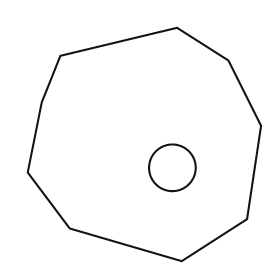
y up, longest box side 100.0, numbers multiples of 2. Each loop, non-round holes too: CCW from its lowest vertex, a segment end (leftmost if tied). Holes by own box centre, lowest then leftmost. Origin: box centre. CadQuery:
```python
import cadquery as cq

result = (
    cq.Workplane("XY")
    .moveTo(16.0, -50.0)
    .lineTo(44.0, -32.0)
    .lineTo(50.0, 8.0)
    .lineTo(36.0, 36.0)
    .lineTo(14.0, 50.0)
    .lineTo(-36.0, 38.0)
    .lineTo(-44.0, 18.0)
    .lineTo(-50.0, -12.0)
    .lineTo(-32.0, -36.0)
    .close()
    .moveTo(12.0, -10.0)
    .circle(10.0)
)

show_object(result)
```